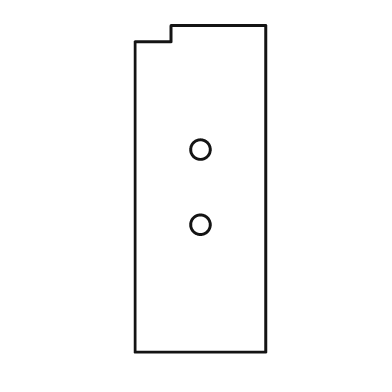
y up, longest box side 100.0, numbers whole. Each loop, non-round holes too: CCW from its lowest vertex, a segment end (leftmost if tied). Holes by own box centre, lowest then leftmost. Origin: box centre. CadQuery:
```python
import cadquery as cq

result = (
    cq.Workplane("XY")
    .moveTo(-20.0, -50.0)
    .lineTo(20.0, -50.0)
    .lineTo(20.0, 50.0)
    .lineTo(-9.0, 50.0)
    .lineTo(-9.0, 45.0)
    .lineTo(-20.0, 45.0)
    .close()
    .moveTo(0.0, -11.0)
    .circle(3.0)
    .moveTo(0.0, 12.0)
    .circle(3.0)
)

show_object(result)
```